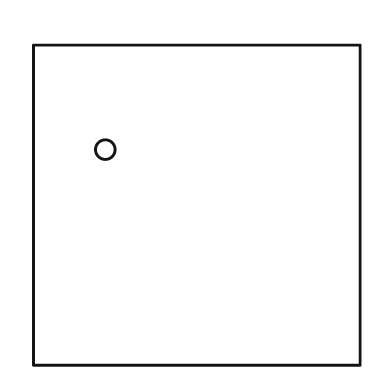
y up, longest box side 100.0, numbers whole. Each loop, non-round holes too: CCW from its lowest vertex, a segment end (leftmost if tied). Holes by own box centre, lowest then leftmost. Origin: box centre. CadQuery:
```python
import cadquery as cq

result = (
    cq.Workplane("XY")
    .moveTo(-50.0, -49.0)
    .lineTo(50.0, -49.0)
    .lineTo(50.0, 49.0)
    .lineTo(-50.0, 49.0)
    .close()
    .moveTo(-28.0, 17.0)
    .circle(3.0)
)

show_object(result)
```